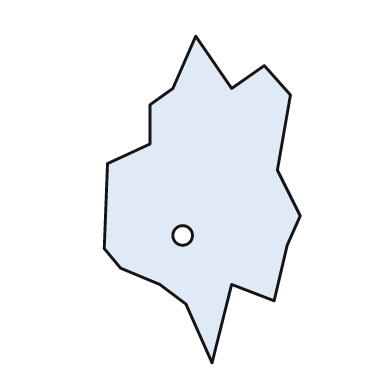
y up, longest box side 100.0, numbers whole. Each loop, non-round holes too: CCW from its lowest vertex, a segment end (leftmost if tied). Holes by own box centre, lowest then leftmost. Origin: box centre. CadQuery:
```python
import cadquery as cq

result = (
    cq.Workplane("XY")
    .moveTo(3.0, -50.0)
    .lineTo(9.0, -26.0)
    .lineTo(22.0, -31.0)
    .lineTo(26.0, -14.0)
    .lineTo(30.0, -5.0)
    .lineTo(23.0, 9.0)
    .lineTo(27.0, 32.0)
    .lineTo(19.0, 41.0)
    .lineTo(9.0, 34.0)
    .lineTo(-2.0, 50.0)
    .lineTo(-9.0, 34.0)
    .lineTo(-16.0, 29.0)
    .lineTo(-16.0, 17.0)
    .lineTo(-29.0, 11.0)
    .lineTo(-30.0, -15.0)
    .lineTo(-25.0, -21.0)
    .lineTo(-13.0, -26.0)
    .lineTo(-5.0, -32.0)
    .close()
    .moveTo(-6.0, -11.0)
    .circle(3.0)
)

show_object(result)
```